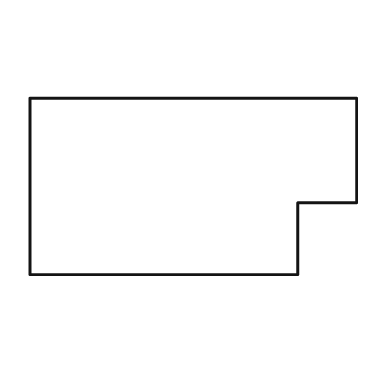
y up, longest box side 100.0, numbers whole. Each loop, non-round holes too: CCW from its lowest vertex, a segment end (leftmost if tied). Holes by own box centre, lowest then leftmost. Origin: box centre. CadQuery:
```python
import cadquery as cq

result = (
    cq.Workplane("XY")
    .moveTo(-50.0, -27.0)
    .lineTo(32.0, -27.0)
    .lineTo(32.0, -5.0)
    .lineTo(50.0, -5.0)
    .lineTo(50.0, 27.0)
    .lineTo(-50.0, 27.0)
    .close()
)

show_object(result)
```